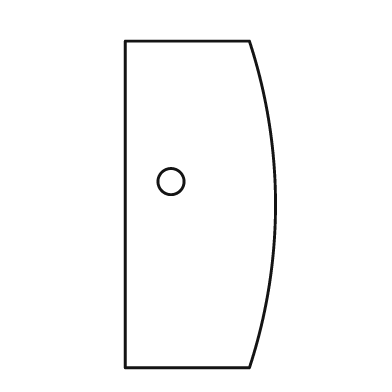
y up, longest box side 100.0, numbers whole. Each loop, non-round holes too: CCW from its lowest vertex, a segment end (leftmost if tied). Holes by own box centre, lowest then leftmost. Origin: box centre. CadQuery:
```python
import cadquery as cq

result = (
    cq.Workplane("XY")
    .moveTo(-23.0, -50.0)
    .lineTo(15.0, -50.0)
    .threePointArc((23.0, 0.0), (15.0, 50.0))
    .lineTo(-23.0, 50.0)
    .close()
    .moveTo(-9.0, 7.0)
    .circle(4.0)
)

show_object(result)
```